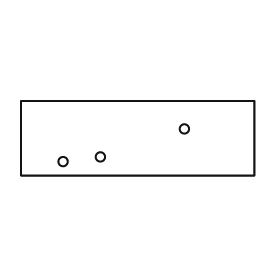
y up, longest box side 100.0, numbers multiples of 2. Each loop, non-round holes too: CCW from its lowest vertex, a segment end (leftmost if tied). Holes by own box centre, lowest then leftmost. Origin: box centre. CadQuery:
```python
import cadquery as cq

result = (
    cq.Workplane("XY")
    .moveTo(-50.0, -16.0)
    .lineTo(50.0, -16.0)
    .lineTo(50.0, 16.0)
    .lineTo(-50.0, 16.0)
    .close()
    .moveTo(-32.0, -10.0)
    .circle(2.0)
    .moveTo(-16.0, -8.0)
    .circle(2.0)
    .moveTo(20.0, 4.0)
    .circle(2.0)
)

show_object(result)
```